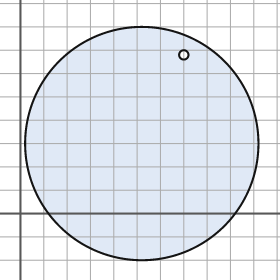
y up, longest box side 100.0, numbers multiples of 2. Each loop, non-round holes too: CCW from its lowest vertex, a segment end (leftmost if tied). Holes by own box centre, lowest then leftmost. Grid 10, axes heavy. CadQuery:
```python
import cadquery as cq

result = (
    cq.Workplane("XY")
    .moveTo(52.0, 30.0)
    .circle(50.0)
    .moveTo(70.0, 68.0)
    .circle(2.0)
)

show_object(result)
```